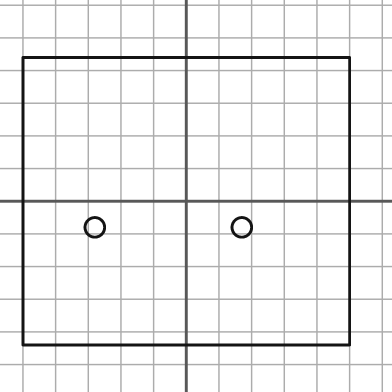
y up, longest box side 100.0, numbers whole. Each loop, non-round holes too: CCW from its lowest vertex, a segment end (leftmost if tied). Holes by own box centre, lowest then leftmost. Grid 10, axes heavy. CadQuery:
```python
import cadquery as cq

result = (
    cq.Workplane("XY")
    .moveTo(-50.0, -44.0)
    .lineTo(50.0, -44.0)
    .lineTo(50.0, 44.0)
    .lineTo(-50.0, 44.0)
    .close()
    .moveTo(-28.0, -8.0)
    .circle(3.0)
    .moveTo(17.0, -8.0)
    .circle(3.0)
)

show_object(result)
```